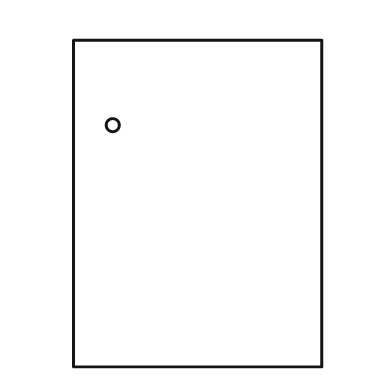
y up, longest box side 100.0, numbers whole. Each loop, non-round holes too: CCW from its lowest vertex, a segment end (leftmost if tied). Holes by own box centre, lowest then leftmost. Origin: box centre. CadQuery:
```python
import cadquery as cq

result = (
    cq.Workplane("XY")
    .moveTo(-38.0, -50.0)
    .lineTo(38.0, -50.0)
    .lineTo(38.0, 50.0)
    .lineTo(-38.0, 50.0)
    .close()
    .moveTo(-26.0, 24.0)
    .circle(2.0)
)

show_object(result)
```